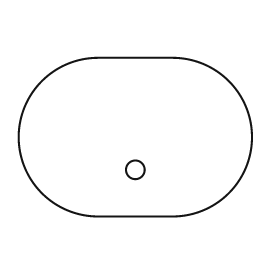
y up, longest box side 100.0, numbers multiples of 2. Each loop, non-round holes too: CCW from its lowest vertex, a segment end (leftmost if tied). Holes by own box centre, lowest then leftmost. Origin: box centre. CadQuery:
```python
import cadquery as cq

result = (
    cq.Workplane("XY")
    .moveTo(-16.0, -34.0)
    .lineTo(16.0, -34.0)
    .threePointArc((50.0, 0.0), (16.0, 34.0))
    .lineTo(-16.0, 34.0)
    .threePointArc((-50.0, 0.0), (-16.0, -34.0))
    .close()
    .moveTo(0.0, -14.0)
    .circle(4.0)
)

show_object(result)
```